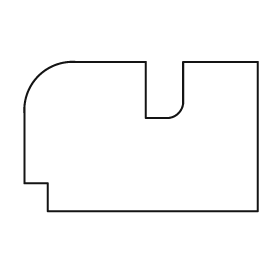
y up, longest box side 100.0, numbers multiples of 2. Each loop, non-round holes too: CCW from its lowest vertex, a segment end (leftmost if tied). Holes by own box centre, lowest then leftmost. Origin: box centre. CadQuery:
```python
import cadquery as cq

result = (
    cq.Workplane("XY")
    .moveTo(-40.0, -32.0)
    .lineTo(50.0, -32.0)
    .lineTo(50.0, 32.0)
    .lineTo(18.0, 32.0)
    .lineTo(18.0, 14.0)
    .threePointArc((16.0, 10.0), (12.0, 8.0))
    .lineTo(2.0, 8.0)
    .lineTo(2.0, 32.0)
    .lineTo(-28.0, 32.0)
    .threePointArc((-44.0, 26.0), (-50.0, 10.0))
    .lineTo(-50.0, -20.0)
    .lineTo(-40.0, -20.0)
    .close()
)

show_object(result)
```